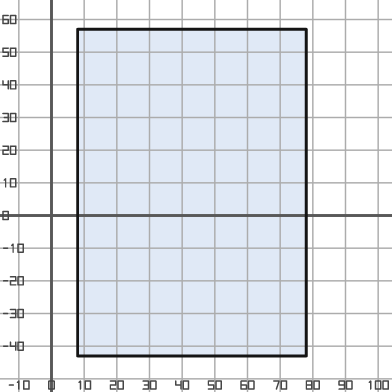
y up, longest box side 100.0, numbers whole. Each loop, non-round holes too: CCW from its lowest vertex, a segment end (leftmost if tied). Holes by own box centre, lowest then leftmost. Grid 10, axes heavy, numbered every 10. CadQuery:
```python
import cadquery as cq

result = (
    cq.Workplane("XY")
    .moveTo(8.0, -43.0)
    .lineTo(78.0, -43.0)
    .lineTo(78.0, 57.0)
    .lineTo(8.0, 57.0)
    .close()
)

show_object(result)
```